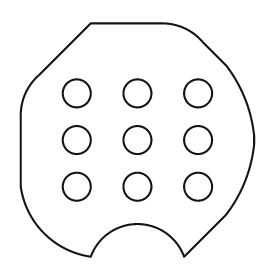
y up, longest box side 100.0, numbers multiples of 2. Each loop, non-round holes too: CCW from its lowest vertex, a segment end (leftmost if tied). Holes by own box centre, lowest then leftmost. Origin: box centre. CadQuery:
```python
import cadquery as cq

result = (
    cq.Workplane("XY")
    .moveTo(-20.0, -50.0)
    .threePointArc((0.0, -36.0), (20.0, -50.0))
    .lineTo(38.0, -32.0)
    .threePointArc((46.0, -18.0), (50.0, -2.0))
    .lineTo(50.0, 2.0)
    .threePointArc((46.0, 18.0), (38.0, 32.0))
    .lineTo(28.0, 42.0)
    .threePointArc((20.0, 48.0), (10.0, 50.0))
    .lineTo(-20.0, 50.0)
    .lineTo(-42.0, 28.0)
    .threePointArc((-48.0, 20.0), (-50.0, 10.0))
    .lineTo(-50.0, -20.0)
    .threePointArc((-40.0, -40.0), (-20.0, -50.0))
    .close()
    .moveTo(-26.0, -20.0)
    .circle(6.0)
    .moveTo(0.0, -20.0)
    .circle(6.0)
    .moveTo(26.0, -20.0)
    .circle(6.0)
    .moveTo(-26.0, 0.0)
    .circle(6.0)
    .moveTo(0.0, 0.0)
    .circle(6.0)
    .moveTo(26.0, 0.0)
    .circle(6.0)
    .moveTo(-26.0, 20.0)
    .circle(6.0)
    .moveTo(0.0, 20.0)
    .circle(6.0)
    .moveTo(26.0, 20.0)
    .circle(6.0)
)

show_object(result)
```